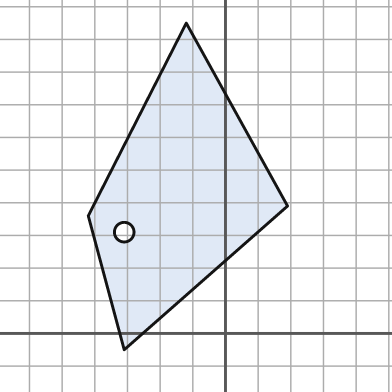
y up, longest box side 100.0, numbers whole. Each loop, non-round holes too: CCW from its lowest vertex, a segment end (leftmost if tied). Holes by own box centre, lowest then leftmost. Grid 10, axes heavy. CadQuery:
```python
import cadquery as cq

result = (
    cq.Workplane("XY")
    .moveTo(-31.0, -5.0)
    .lineTo(19.0, 39.0)
    .lineTo(-12.0, 95.0)
    .lineTo(-42.0, 36.0)
    .close()
    .moveTo(-31.0, 31.0)
    .circle(3.0)
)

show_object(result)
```